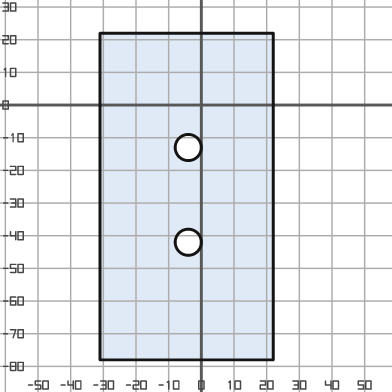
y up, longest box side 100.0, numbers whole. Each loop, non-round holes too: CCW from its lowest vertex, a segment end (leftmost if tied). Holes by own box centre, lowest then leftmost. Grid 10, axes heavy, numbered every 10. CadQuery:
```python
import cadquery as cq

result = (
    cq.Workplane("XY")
    .moveTo(-31.0, -78.0)
    .lineTo(22.0, -78.0)
    .lineTo(22.0, 22.0)
    .lineTo(-31.0, 22.0)
    .close()
    .moveTo(-4.0, -42.0)
    .circle(4.0)
    .moveTo(-4.0, -13.0)
    .circle(4.0)
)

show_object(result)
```